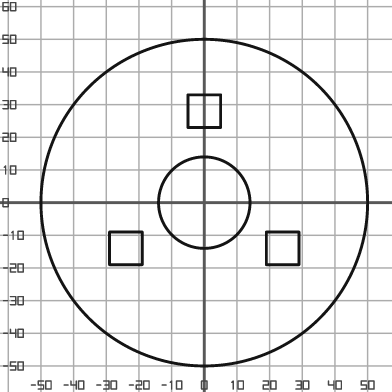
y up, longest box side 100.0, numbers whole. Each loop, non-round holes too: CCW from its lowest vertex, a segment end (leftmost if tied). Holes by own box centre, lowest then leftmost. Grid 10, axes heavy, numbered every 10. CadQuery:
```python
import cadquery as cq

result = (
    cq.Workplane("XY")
    .moveTo(0.0, 0.0)
    .circle(50.0)
    .moveTo(-29.0, -19.0)
    .lineTo(-19.0, -19.0)
    .lineTo(-19.0, -9.0)
    .lineTo(-29.0, -9.0)
    .close()
    .moveTo(19.0, -19.0)
    .lineTo(29.0, -19.0)
    .lineTo(29.0, -9.0)
    .lineTo(19.0, -9.0)
    .close()
    .moveTo(0.0, 0.0)
    .circle(14.0)
    .moveTo(-5.0, 23.0)
    .lineTo(5.0, 23.0)
    .lineTo(5.0, 33.0)
    .lineTo(-5.0, 33.0)
    .close()
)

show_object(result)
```